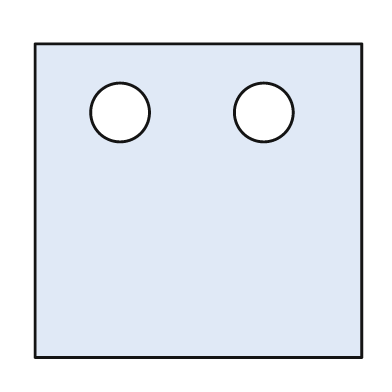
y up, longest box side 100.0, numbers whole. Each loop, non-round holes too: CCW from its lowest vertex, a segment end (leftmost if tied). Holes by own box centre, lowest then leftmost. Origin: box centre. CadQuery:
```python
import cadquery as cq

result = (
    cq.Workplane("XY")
    .moveTo(-50.0, -48.0)
    .lineTo(50.0, -48.0)
    .lineTo(50.0, 48.0)
    .lineTo(-50.0, 48.0)
    .close()
    .moveTo(-24.0, 27.0)
    .circle(9.0)
    .moveTo(20.0, 27.0)
    .circle(9.0)
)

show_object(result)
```